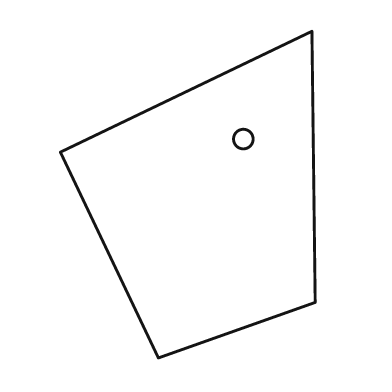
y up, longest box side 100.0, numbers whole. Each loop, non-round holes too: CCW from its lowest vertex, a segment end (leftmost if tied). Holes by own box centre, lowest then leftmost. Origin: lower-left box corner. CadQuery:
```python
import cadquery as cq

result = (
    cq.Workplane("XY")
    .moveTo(30.0, 0.0)
    .lineTo(78.0, 17.0)
    .lineTo(77.0, 100.0)
    .lineTo(0.0, 63.0)
    .close()
    .moveTo(56.0, 67.0)
    .circle(3.0)
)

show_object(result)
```